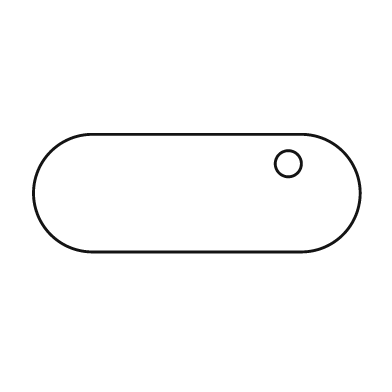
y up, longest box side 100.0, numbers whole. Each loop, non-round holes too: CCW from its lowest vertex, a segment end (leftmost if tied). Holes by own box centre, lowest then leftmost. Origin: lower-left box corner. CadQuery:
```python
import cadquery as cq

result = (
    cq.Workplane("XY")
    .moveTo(18.0, 0.0)
    .lineTo(82.0, 0.0)
    .threePointArc((100.0, 18.0), (82.0, 36.0))
    .lineTo(18.0, 36.0)
    .threePointArc((0.0, 18.0), (18.0, 0.0))
    .close()
    .moveTo(78.0, 27.0)
    .circle(4.0)
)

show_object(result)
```